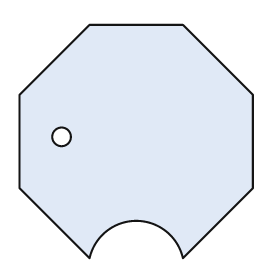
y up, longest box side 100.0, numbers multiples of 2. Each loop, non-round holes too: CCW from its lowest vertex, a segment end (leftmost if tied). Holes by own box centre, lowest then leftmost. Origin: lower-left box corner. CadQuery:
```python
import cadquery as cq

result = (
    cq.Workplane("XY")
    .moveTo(30.0, 0.0)
    .threePointArc((50.0, 16.0), (70.0, 0.0))
    .lineTo(100.0, 30.0)
    .lineTo(100.0, 70.0)
    .lineTo(70.0, 100.0)
    .lineTo(30.0, 100.0)
    .lineTo(0.0, 70.0)
    .lineTo(0.0, 30.0)
    .close()
    .moveTo(18.0, 52.0)
    .circle(4.0)
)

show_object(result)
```